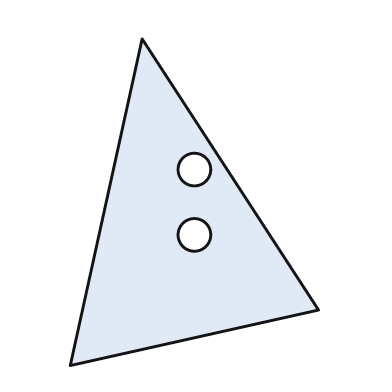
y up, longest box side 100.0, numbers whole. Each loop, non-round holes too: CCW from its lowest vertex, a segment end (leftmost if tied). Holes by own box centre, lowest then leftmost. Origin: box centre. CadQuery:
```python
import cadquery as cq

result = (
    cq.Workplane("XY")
    .moveTo(-38.0, -50.0)
    .lineTo(38.0, -33.0)
    .lineTo(-16.0, 50.0)
    .close()
    .moveTo(0.0, -10.0)
    .circle(5.0)
    .moveTo(0.0, 10.0)
    .circle(5.0)
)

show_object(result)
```